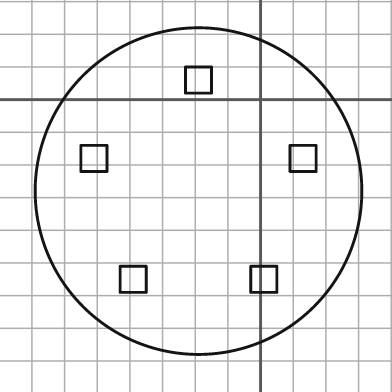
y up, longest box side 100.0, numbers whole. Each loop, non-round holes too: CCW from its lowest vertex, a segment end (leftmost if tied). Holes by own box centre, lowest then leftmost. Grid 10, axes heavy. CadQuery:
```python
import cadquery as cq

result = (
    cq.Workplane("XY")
    .moveTo(-19.0, -28.0)
    .circle(50.0)
    .moveTo(-43.0, -59.0)
    .lineTo(-35.0, -59.0)
    .lineTo(-35.0, -51.0)
    .lineTo(-43.0, -51.0)
    .close()
    .moveTo(-3.0, -59.0)
    .lineTo(5.0, -59.0)
    .lineTo(5.0, -51.0)
    .lineTo(-3.0, -51.0)
    .close()
    .moveTo(-55.0, -22.0)
    .lineTo(-47.0, -22.0)
    .lineTo(-47.0, -14.0)
    .lineTo(-55.0, -14.0)
    .close()
    .moveTo(9.0, -22.0)
    .lineTo(17.0, -22.0)
    .lineTo(17.0, -14.0)
    .lineTo(9.0, -14.0)
    .close()
    .moveTo(-23.0, 2.0)
    .lineTo(-15.0, 2.0)
    .lineTo(-15.0, 10.0)
    .lineTo(-23.0, 10.0)
    .close()
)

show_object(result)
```